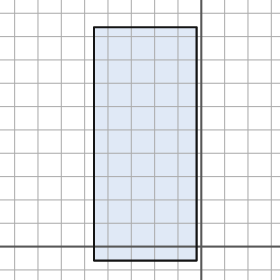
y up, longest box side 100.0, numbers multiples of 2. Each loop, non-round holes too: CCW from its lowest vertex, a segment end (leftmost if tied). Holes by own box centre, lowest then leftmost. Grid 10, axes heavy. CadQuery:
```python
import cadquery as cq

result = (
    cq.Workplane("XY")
    .moveTo(-46.0, -6.0)
    .lineTo(-2.0, -6.0)
    .lineTo(-2.0, 94.0)
    .lineTo(-46.0, 94.0)
    .close()
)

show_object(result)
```